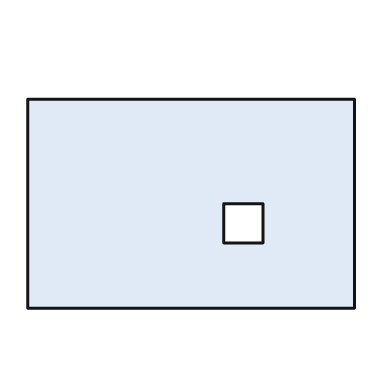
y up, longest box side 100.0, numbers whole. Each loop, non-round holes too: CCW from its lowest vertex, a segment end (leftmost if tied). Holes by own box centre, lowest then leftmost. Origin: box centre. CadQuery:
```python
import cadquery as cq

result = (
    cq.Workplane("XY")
    .moveTo(-50.0, -32.0)
    .lineTo(50.0, -32.0)
    .lineTo(50.0, 32.0)
    .lineTo(-50.0, 32.0)
    .close()
    .moveTo(10.0, -12.0)
    .lineTo(22.0, -12.0)
    .lineTo(22.0, 0.0)
    .lineTo(10.0, 0.0)
    .close()
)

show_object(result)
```